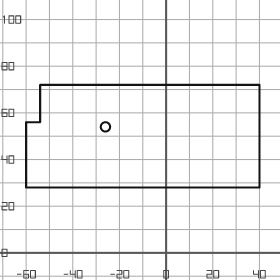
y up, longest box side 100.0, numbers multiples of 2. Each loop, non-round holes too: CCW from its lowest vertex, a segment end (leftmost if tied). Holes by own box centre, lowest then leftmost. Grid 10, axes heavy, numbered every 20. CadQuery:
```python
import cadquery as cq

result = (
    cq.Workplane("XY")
    .moveTo(-60.0, 28.0)
    .lineTo(40.0, 28.0)
    .lineTo(40.0, 72.0)
    .lineTo(-54.0, 72.0)
    .lineTo(-54.0, 56.0)
    .lineTo(-60.0, 56.0)
    .close()
    .moveTo(-26.0, 54.0)
    .circle(2.0)
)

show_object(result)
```